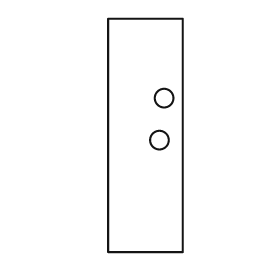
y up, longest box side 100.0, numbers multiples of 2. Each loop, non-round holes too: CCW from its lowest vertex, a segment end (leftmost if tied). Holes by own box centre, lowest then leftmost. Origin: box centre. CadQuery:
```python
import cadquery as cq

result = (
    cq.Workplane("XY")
    .moveTo(-16.0, -50.0)
    .lineTo(16.0, -50.0)
    .lineTo(16.0, 50.0)
    .lineTo(-16.0, 50.0)
    .close()
    .moveTo(6.0, -2.0)
    .circle(4.0)
    .moveTo(8.0, 16.0)
    .circle(4.0)
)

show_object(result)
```